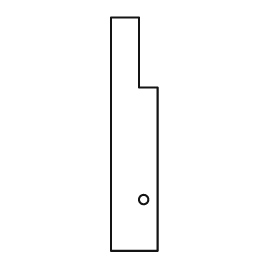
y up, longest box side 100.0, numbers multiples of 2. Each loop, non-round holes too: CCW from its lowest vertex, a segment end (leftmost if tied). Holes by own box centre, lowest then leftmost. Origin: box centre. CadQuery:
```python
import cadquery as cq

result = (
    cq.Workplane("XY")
    .moveTo(-10.0, -50.0)
    .lineTo(10.0, -50.0)
    .lineTo(10.0, 20.0)
    .lineTo(2.0, 20.0)
    .lineTo(2.0, 50.0)
    .lineTo(-10.0, 50.0)
    .close()
    .moveTo(4.0, -28.0)
    .circle(2.0)
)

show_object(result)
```